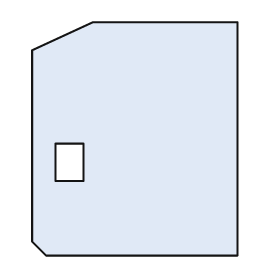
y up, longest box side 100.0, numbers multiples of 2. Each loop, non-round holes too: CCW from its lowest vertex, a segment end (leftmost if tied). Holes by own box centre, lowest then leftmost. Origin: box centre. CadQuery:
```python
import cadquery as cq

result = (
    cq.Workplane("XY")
    .moveTo(-38.0, -50.0)
    .lineTo(44.0, -50.0)
    .lineTo(44.0, 50.0)
    .lineTo(-18.0, 50.0)
    .lineTo(-44.0, 38.0)
    .lineTo(-44.0, -44.0)
    .close()
    .moveTo(-34.0, -18.0)
    .lineTo(-22.0, -18.0)
    .lineTo(-22.0, -2.0)
    .lineTo(-34.0, -2.0)
    .close()
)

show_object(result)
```